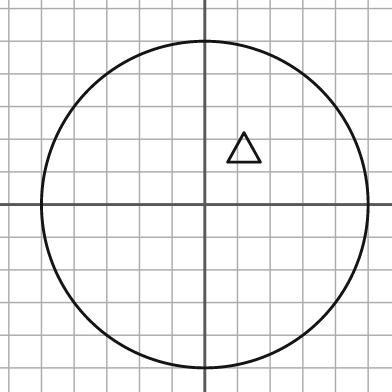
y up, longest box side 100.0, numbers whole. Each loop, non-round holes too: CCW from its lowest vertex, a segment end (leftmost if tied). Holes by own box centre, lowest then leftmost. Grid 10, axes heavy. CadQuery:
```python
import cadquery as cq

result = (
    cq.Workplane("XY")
    .moveTo(0.0, 0.0)
    .circle(50.0)
    .moveTo(7.0, 13.0)
    .lineTo(17.0, 13.0)
    .lineTo(12.0, 22.0)
    .close()
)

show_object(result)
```